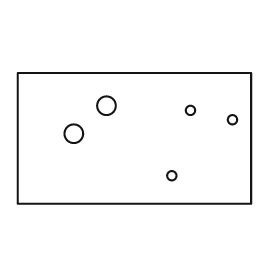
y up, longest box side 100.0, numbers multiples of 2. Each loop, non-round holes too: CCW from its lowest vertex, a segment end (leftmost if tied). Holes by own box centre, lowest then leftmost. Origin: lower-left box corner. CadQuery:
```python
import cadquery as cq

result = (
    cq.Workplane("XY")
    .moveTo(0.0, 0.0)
    .lineTo(100.0, 0.0)
    .lineTo(100.0, 56.0)
    .lineTo(0.0, 56.0)
    .close()
    .moveTo(66.0, 12.0)
    .circle(2.0)
    .moveTo(24.0, 30.0)
    .circle(4.0)
    .moveTo(92.0, 36.0)
    .circle(2.0)
    .moveTo(74.0, 40.0)
    .circle(2.0)
    .moveTo(38.0, 42.0)
    .circle(4.0)
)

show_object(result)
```